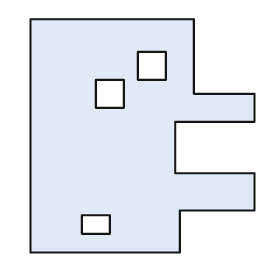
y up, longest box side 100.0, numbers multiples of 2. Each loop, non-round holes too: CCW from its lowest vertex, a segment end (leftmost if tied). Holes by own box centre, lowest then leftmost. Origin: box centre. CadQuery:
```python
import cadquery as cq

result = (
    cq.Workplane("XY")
    .moveTo(-48.0, -50.0)
    .lineTo(16.0, -50.0)
    .lineTo(16.0, -32.0)
    .lineTo(48.0, -32.0)
    .lineTo(48.0, -16.0)
    .lineTo(14.0, -16.0)
    .lineTo(14.0, 6.0)
    .lineTo(48.0, 6.0)
    .lineTo(48.0, 18.0)
    .lineTo(22.0, 18.0)
    .lineTo(22.0, 50.0)
    .lineTo(-48.0, 50.0)
    .close()
    .moveTo(-26.0, -42.0)
    .lineTo(-14.0, -42.0)
    .lineTo(-14.0, -34.0)
    .lineTo(-26.0, -34.0)
    .close()
    .moveTo(-20.0, 12.0)
    .lineTo(-8.0, 12.0)
    .lineTo(-8.0, 24.0)
    .lineTo(-20.0, 24.0)
    .close()
    .moveTo(-2.0, 24.0)
    .lineTo(10.0, 24.0)
    .lineTo(10.0, 36.0)
    .lineTo(-2.0, 36.0)
    .close()
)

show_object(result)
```